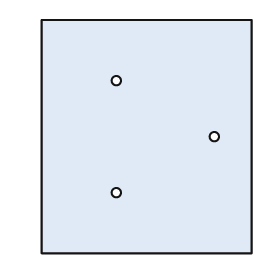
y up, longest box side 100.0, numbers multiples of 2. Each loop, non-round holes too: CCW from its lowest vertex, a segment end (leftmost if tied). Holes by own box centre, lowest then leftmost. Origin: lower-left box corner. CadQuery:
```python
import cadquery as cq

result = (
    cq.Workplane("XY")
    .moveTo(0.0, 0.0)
    .lineTo(90.0, 0.0)
    .lineTo(90.0, 100.0)
    .lineTo(0.0, 100.0)
    .close()
    .moveTo(32.0, 26.0)
    .circle(2.0)
    .moveTo(74.0, 50.0)
    .circle(2.0)
    .moveTo(32.0, 74.0)
    .circle(2.0)
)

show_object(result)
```